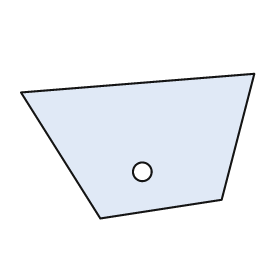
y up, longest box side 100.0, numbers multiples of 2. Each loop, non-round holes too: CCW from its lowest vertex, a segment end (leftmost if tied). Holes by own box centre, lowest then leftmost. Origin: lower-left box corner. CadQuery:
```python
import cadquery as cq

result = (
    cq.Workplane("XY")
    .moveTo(34.0, 0.0)
    .lineTo(86.0, 8.0)
    .lineTo(100.0, 62.0)
    .lineTo(0.0, 54.0)
    .close()
    .moveTo(52.0, 20.0)
    .circle(4.0)
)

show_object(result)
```